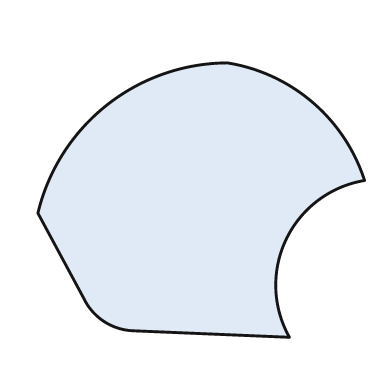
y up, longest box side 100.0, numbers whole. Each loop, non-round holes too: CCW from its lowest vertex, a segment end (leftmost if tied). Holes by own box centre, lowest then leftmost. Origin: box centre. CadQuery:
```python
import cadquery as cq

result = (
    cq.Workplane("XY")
    .moveTo(27.0, -42.0)
    .threePointArc((26.0, -12.0), (50.0, 6.0))
    .threePointArc((34.0, 30.0), (8.0, 42.0))
    .threePointArc((-29.0, 29.0), (-50.0, -4.0))
    .lineTo(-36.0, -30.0)
    .threePointArc((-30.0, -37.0), (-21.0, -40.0))
    .close()
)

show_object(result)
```